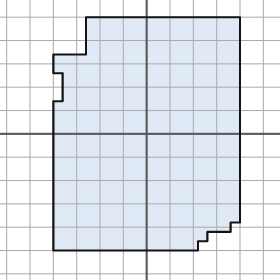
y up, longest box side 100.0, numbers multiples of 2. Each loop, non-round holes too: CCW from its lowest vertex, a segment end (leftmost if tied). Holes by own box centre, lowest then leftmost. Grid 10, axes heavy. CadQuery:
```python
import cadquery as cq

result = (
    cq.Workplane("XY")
    .moveTo(-40.0, -50.0)
    .lineTo(22.0, -50.0)
    .lineTo(22.0, -46.0)
    .lineTo(26.0, -46.0)
    .lineTo(26.0, -42.0)
    .lineTo(36.0, -42.0)
    .lineTo(36.0, -38.0)
    .lineTo(40.0, -38.0)
    .lineTo(40.0, 50.0)
    .lineTo(-26.0, 50.0)
    .lineTo(-26.0, 34.0)
    .lineTo(-40.0, 34.0)
    .lineTo(-40.0, 26.0)
    .lineTo(-36.0, 26.0)
    .lineTo(-36.0, 14.0)
    .lineTo(-40.0, 14.0)
    .close()
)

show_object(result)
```